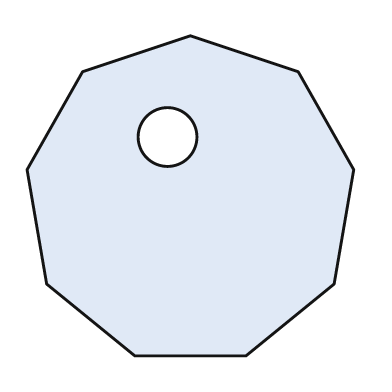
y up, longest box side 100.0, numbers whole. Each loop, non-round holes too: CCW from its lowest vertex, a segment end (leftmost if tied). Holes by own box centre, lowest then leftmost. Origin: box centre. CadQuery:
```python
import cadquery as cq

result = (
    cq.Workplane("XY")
    .moveTo(-17.0, -49.0)
    .lineTo(17.0, -49.0)
    .lineTo(44.0, -27.0)
    .lineTo(50.0, 8.0)
    .lineTo(33.0, 38.0)
    .lineTo(0.0, 49.0)
    .lineTo(-33.0, 38.0)
    .lineTo(-50.0, 8.0)
    .lineTo(-44.0, -27.0)
    .close()
    .moveTo(-7.0, 18.0)
    .circle(9.0)
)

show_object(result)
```